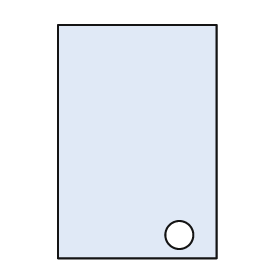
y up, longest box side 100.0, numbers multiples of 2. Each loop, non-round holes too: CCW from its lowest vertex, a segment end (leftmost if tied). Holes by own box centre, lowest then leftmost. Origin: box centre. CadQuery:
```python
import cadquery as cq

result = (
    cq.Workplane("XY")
    .moveTo(-34.0, -50.0)
    .lineTo(34.0, -50.0)
    .lineTo(34.0, 50.0)
    .lineTo(-34.0, 50.0)
    .close()
    .moveTo(18.0, -40.0)
    .circle(6.0)
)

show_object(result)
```